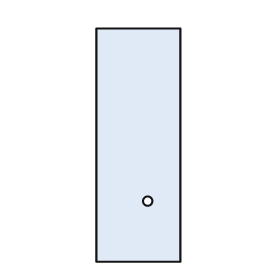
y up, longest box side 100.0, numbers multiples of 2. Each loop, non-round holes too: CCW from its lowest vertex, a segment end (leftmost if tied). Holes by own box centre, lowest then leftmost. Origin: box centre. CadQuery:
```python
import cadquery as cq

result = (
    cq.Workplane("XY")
    .moveTo(-18.0, -50.0)
    .lineTo(18.0, -50.0)
    .lineTo(18.0, 50.0)
    .lineTo(-18.0, 50.0)
    .close()
    .moveTo(4.0, -24.0)
    .circle(2.0)
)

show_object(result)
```